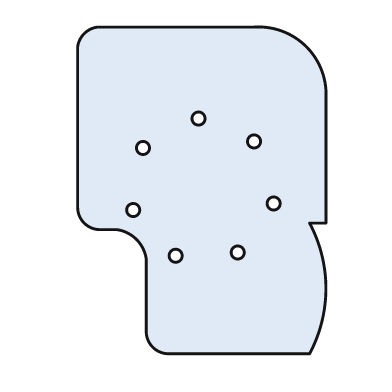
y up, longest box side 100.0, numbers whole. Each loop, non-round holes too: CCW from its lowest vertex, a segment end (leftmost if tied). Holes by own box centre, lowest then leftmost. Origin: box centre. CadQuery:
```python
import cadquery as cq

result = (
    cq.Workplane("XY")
    .moveTo(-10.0, -50.0)
    .lineTo(33.0, -50.0)
    .threePointArc((38.0, -30.0), (33.0, -10.0))
    .lineTo(38.0, -10.0)
    .lineTo(38.0, 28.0)
    .threePointArc((32.0, 44.0), (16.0, 50.0))
    .lineTo(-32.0, 50.0)
    .threePointArc((-36.0, 48.0), (-38.0, 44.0))
    .lineTo(-38.0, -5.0)
    .threePointArc((-36.0, -10.0), (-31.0, -12.0))
    .lineTo(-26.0, -12.0)
    .threePointArc((-20.0, -15.0), (-17.0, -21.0))
    .lineTo(-17.0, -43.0)
    .threePointArc((-15.0, -48.0), (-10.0, -50.0))
    .close()
    .moveTo(-8.0, -20.0)
    .circle(2.0)
    .moveTo(11.0, -19.0)
    .circle(2.0)
    .moveTo(-21.0, -6.0)
    .circle(2.0)
    .moveTo(22.0, -4.0)
    .circle(2.0)
    .moveTo(-18.0, 13.0)
    .circle(2.0)
    .moveTo(16.0, 15.0)
    .circle(2.0)
    .moveTo(-1.0, 22.0)
    .circle(2.0)
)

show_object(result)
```